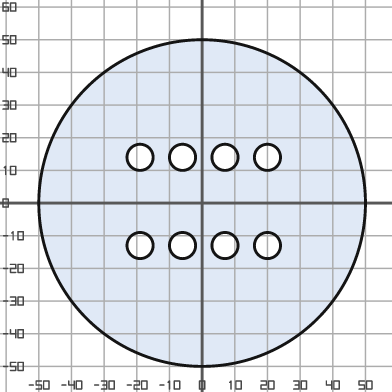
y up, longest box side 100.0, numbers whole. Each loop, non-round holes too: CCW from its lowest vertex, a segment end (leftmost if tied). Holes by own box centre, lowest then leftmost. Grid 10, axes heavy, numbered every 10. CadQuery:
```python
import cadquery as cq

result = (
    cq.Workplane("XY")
    .moveTo(0.0, 0.0)
    .circle(50.0)
    .moveTo(-19.0, -13.0)
    .circle(4.0)
    .moveTo(-6.0, -13.0)
    .circle(4.0)
    .moveTo(7.0, -13.0)
    .circle(4.0)
    .moveTo(20.0, -13.0)
    .circle(4.0)
    .moveTo(-19.0, 14.0)
    .circle(4.0)
    .moveTo(-6.0, 14.0)
    .circle(4.0)
    .moveTo(7.0, 14.0)
    .circle(4.0)
    .moveTo(20.0, 14.0)
    .circle(4.0)
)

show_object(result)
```